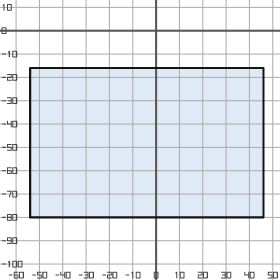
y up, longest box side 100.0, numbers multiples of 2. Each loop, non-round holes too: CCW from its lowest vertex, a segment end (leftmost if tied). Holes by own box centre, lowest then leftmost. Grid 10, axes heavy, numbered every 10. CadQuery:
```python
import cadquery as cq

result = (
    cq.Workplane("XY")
    .moveTo(-54.0, -80.0)
    .lineTo(46.0, -80.0)
    .lineTo(46.0, -16.0)
    .lineTo(-54.0, -16.0)
    .close()
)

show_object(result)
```